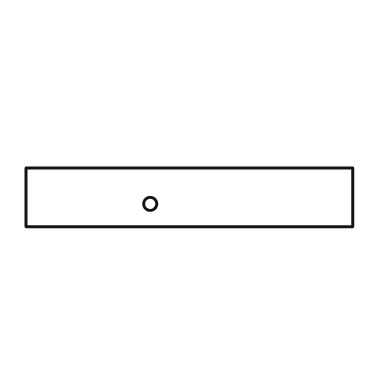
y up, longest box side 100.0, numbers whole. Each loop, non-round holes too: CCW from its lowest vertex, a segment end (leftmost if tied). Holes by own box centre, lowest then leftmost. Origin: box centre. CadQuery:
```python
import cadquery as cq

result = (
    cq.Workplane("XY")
    .moveTo(-50.0, -9.0)
    .lineTo(50.0, -9.0)
    .lineTo(50.0, 9.0)
    .lineTo(-50.0, 9.0)
    .close()
    .moveTo(-12.0, -2.0)
    .circle(2.0)
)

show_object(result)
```